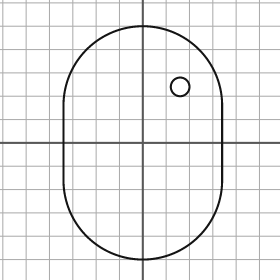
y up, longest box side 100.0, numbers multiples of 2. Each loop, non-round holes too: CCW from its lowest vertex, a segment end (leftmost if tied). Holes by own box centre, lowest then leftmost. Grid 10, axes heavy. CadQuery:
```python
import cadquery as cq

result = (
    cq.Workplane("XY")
    .moveTo(-34.0, -16.0)
    .threePointArc((0.0, -50.0), (34.0, -16.0))
    .lineTo(34.0, 16.0)
    .threePointArc((0.0, 50.0), (-34.0, 16.0))
    .close()
    .moveTo(16.0, 24.0)
    .circle(4.0)
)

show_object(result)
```